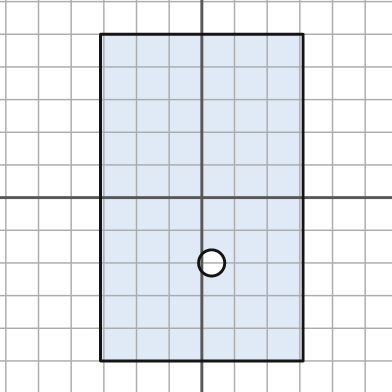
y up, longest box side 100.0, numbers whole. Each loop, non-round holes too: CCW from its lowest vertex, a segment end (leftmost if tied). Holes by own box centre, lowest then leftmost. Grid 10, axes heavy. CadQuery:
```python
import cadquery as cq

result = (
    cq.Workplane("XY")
    .moveTo(-31.0, -50.0)
    .lineTo(31.0, -50.0)
    .lineTo(31.0, 50.0)
    .lineTo(-31.0, 50.0)
    .close()
    .moveTo(3.0, -20.0)
    .circle(4.0)
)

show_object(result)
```